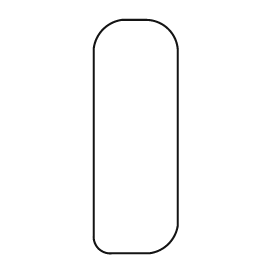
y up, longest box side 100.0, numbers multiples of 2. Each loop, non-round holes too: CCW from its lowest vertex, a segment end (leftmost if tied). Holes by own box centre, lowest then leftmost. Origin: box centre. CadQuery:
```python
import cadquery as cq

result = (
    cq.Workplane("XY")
    .moveTo(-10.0, -50.0)
    .lineTo(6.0, -50.0)
    .threePointArc((14.0, -46.0), (18.0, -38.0))
    .lineTo(18.0, 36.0)
    .threePointArc((14.0, 46.0), (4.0, 50.0))
    .lineTo(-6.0, 50.0)
    .threePointArc((-14.0, 46.0), (-18.0, 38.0))
    .lineTo(-18.0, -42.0)
    .threePointArc((-16.0, -48.0), (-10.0, -50.0))
    .close()
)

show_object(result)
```